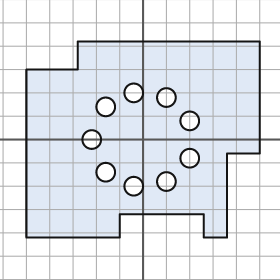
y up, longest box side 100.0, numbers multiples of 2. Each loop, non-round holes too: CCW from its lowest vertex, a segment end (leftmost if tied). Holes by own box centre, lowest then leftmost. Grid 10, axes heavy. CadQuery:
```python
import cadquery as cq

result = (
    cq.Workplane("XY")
    .moveTo(-50.0, -42.0)
    .lineTo(-10.0, -42.0)
    .lineTo(-10.0, -32.0)
    .lineTo(26.0, -32.0)
    .lineTo(26.0, -42.0)
    .lineTo(36.0, -42.0)
    .lineTo(36.0, -6.0)
    .lineTo(50.0, -6.0)
    .lineTo(50.0, 42.0)
    .lineTo(-28.0, 42.0)
    .lineTo(-28.0, 30.0)
    .lineTo(-50.0, 30.0)
    .close()
    .moveTo(-4.0, -20.0)
    .circle(4.0)
    .moveTo(10.0, -18.0)
    .circle(4.0)
    .moveTo(-16.0, -14.0)
    .circle(4.0)
    .moveTo(20.0, -8.0)
    .circle(4.0)
    .moveTo(-22.0, 0.0)
    .circle(4.0)
    .moveTo(20.0, 8.0)
    .circle(4.0)
    .moveTo(-16.0, 14.0)
    .circle(4.0)
    .moveTo(10.0, 18.0)
    .circle(4.0)
    .moveTo(-4.0, 20.0)
    .circle(4.0)
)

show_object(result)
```